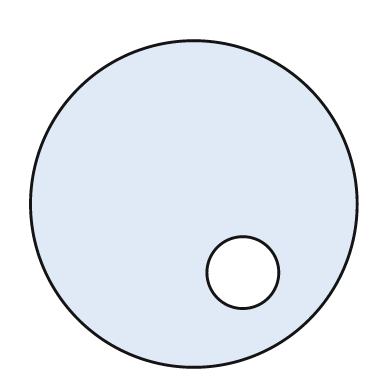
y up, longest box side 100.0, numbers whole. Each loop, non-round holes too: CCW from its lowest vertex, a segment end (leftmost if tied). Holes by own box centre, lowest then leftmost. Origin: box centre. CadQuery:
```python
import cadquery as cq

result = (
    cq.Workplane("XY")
    .moveTo(0.0, 0.0)
    .circle(50.0)
    .moveTo(15.0, -21.0)
    .circle(11.0)
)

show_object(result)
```